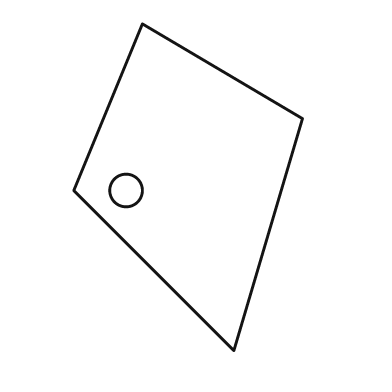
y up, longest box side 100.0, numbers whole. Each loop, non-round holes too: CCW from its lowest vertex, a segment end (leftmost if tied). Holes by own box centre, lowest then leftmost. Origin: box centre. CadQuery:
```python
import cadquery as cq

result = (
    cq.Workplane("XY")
    .moveTo(14.0, -50.0)
    .lineTo(35.0, 21.0)
    .lineTo(-14.0, 50.0)
    .lineTo(-35.0, -1.0)
    .close()
    .moveTo(-19.0, -1.0)
    .circle(5.0)
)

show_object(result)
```